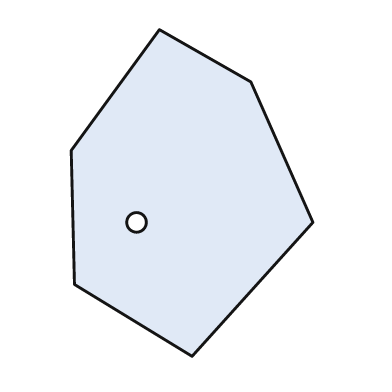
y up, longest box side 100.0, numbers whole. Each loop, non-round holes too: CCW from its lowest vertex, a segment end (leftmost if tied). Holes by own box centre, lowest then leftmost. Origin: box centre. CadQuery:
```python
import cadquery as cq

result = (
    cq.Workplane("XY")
    .moveTo(0.0, -50.0)
    .lineTo(37.0, -9.0)
    .lineTo(18.0, 34.0)
    .lineTo(-10.0, 50.0)
    .lineTo(-37.0, 13.0)
    .lineTo(-36.0, -28.0)
    .close()
    .moveTo(-17.0, -9.0)
    .circle(3.0)
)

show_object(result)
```